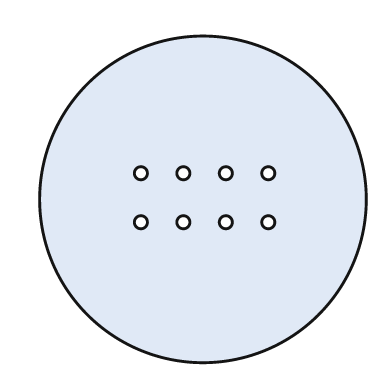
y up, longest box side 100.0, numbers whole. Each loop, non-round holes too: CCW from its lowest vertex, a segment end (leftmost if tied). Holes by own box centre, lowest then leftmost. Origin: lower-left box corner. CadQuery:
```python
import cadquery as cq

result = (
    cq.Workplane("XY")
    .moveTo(50.0, 50.0)
    .circle(50.0)
    .moveTo(31.0, 43.0)
    .circle(2.0)
    .moveTo(44.0, 43.0)
    .circle(2.0)
    .moveTo(57.0, 43.0)
    .circle(2.0)
    .moveTo(70.0, 43.0)
    .circle(2.0)
    .moveTo(31.0, 58.0)
    .circle(2.0)
    .moveTo(44.0, 58.0)
    .circle(2.0)
    .moveTo(57.0, 58.0)
    .circle(2.0)
    .moveTo(70.0, 58.0)
    .circle(2.0)
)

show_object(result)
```